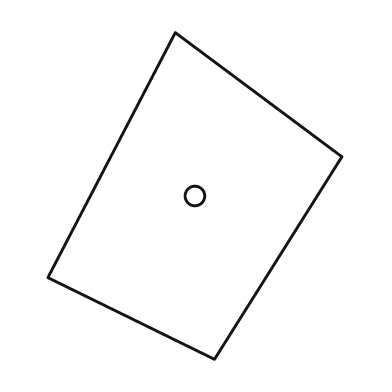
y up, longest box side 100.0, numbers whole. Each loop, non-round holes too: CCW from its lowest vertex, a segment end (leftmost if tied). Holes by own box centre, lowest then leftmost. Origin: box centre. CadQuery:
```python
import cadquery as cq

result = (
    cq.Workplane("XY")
    .moveTo(6.0, -50.0)
    .lineTo(45.0, 12.0)
    .lineTo(-6.0, 50.0)
    .lineTo(-45.0, -25.0)
    .close()
    .moveTo(0.0, 0.0)
    .circle(3.0)
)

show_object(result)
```